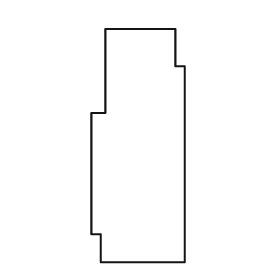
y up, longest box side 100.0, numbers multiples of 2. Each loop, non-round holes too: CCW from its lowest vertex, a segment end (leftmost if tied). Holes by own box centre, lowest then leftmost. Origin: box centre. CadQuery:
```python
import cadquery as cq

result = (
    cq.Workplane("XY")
    .moveTo(-16.0, -50.0)
    .lineTo(20.0, -50.0)
    .lineTo(20.0, 34.0)
    .lineTo(16.0, 34.0)
    .lineTo(16.0, 50.0)
    .lineTo(-14.0, 50.0)
    .lineTo(-14.0, 14.0)
    .lineTo(-20.0, 14.0)
    .lineTo(-20.0, -38.0)
    .lineTo(-16.0, -38.0)
    .close()
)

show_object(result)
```